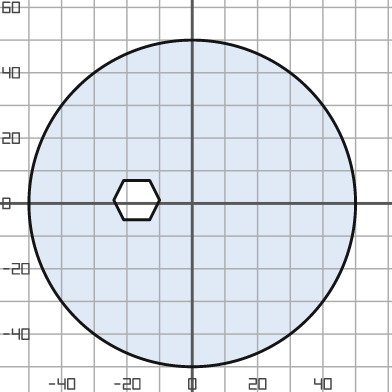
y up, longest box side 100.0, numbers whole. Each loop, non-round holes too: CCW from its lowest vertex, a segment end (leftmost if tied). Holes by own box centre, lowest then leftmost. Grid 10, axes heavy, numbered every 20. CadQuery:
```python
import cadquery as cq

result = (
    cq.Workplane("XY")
    .moveTo(0.0, 0.0)
    .circle(50.0)
    .moveTo(-21.0, -5.0)
    .lineTo(-13.0, -5.0)
    .lineTo(-10.0, 1.0)
    .lineTo(-13.0, 7.0)
    .lineTo(-21.0, 7.0)
    .lineTo(-24.0, 1.0)
    .close()
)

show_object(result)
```